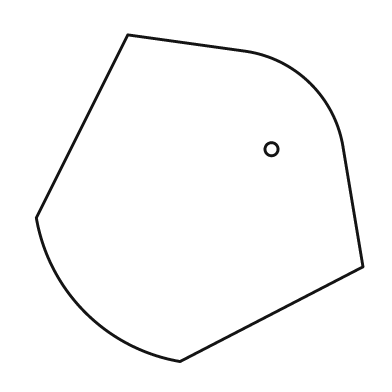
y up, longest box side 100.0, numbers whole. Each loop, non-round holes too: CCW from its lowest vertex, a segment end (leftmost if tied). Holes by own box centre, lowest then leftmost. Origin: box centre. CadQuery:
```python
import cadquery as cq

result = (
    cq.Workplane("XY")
    .moveTo(-6.0, -50.0)
    .lineTo(50.0, -21.0)
    .lineTo(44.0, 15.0)
    .threePointArc((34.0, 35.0), (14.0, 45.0))
    .lineTo(-22.0, 50.0)
    .lineTo(-50.0, -6.0)
    .threePointArc((-35.0, -35.0), (-6.0, -50.0))
    .close()
    .moveTo(22.0, 15.0)
    .circle(2.0)
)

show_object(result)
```